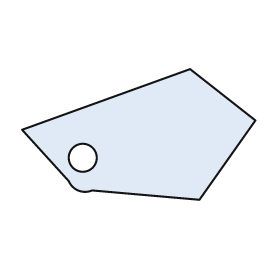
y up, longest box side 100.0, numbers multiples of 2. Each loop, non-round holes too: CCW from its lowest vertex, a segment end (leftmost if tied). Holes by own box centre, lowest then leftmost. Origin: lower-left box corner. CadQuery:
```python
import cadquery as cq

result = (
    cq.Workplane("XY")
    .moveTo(76.0, 0.0)
    .lineTo(100.0, 34.0)
    .lineTo(72.0, 56.0)
    .lineTo(0.0, 30.0)
    .lineTo(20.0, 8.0)
    .threePointArc((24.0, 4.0), (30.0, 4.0))
    .close()
    .moveTo(26.0, 18.0)
    .circle(6.0)
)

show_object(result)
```